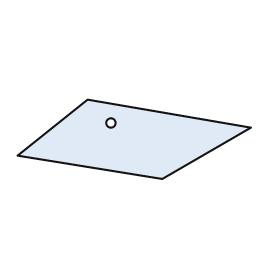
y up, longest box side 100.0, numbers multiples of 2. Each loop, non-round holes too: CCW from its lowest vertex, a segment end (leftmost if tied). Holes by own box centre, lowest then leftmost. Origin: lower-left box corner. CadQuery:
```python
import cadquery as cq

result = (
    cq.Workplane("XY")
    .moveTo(62.0, 0.0)
    .lineTo(100.0, 22.0)
    .lineTo(30.0, 34.0)
    .lineTo(0.0, 10.0)
    .close()
    .moveTo(40.0, 24.0)
    .circle(2.0)
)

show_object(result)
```